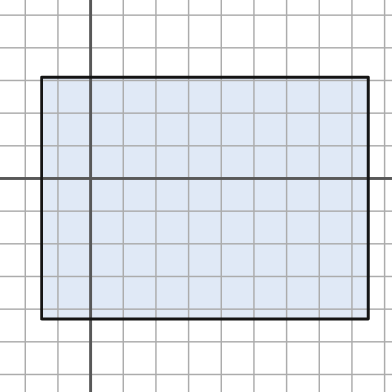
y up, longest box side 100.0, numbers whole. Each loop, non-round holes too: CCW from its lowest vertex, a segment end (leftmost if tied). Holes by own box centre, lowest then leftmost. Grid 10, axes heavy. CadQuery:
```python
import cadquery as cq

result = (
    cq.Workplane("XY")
    .moveTo(-15.0, -43.0)
    .lineTo(85.0, -43.0)
    .lineTo(85.0, 31.0)
    .lineTo(-15.0, 31.0)
    .close()
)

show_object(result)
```